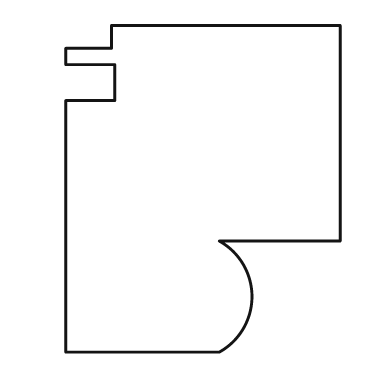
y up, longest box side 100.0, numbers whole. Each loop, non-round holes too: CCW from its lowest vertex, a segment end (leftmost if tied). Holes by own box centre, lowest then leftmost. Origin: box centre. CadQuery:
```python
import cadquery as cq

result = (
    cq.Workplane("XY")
    .moveTo(-42.0, -50.0)
    .lineTo(5.0, -50.0)
    .threePointArc((15.0, -33.0), (5.0, -16.0))
    .lineTo(42.0, -16.0)
    .lineTo(42.0, 50.0)
    .lineTo(-28.0, 50.0)
    .lineTo(-28.0, 43.0)
    .lineTo(-42.0, 43.0)
    .lineTo(-42.0, 38.0)
    .lineTo(-27.0, 38.0)
    .lineTo(-27.0, 27.0)
    .lineTo(-42.0, 27.0)
    .close()
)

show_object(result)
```